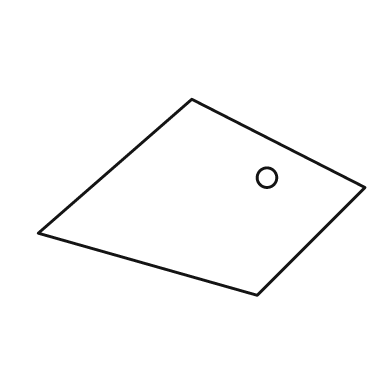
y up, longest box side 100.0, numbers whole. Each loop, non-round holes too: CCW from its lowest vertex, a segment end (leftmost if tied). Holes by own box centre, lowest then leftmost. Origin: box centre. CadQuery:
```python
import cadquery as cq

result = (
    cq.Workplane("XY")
    .moveTo(17.0, -30.0)
    .lineTo(50.0, 3.0)
    .lineTo(-3.0, 30.0)
    .lineTo(-50.0, -11.0)
    .close()
    .moveTo(20.0, 6.0)
    .circle(3.0)
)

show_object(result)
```